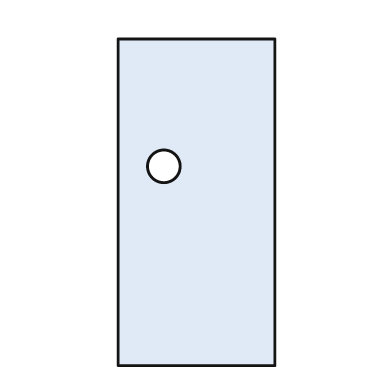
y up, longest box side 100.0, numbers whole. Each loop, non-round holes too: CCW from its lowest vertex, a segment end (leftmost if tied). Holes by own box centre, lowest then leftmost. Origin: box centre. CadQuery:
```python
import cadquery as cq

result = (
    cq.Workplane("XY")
    .moveTo(-24.0, -50.0)
    .lineTo(24.0, -50.0)
    .lineTo(24.0, 50.0)
    .lineTo(-24.0, 50.0)
    .close()
    .moveTo(-10.0, 11.0)
    .circle(5.0)
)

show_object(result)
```